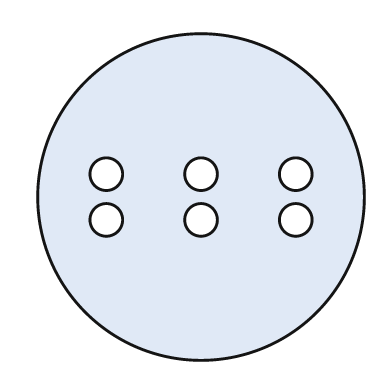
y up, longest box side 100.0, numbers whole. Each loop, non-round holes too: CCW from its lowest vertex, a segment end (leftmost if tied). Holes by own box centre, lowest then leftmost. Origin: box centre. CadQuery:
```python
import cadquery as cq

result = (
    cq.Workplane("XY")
    .moveTo(0.0, 0.0)
    .circle(50.0)
    .moveTo(-29.0, -7.0)
    .circle(5.0)
    .moveTo(0.0, -7.0)
    .circle(5.0)
    .moveTo(29.0, -7.0)
    .circle(5.0)
    .moveTo(-29.0, 7.0)
    .circle(5.0)
    .moveTo(0.0, 7.0)
    .circle(5.0)
    .moveTo(29.0, 7.0)
    .circle(5.0)
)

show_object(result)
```